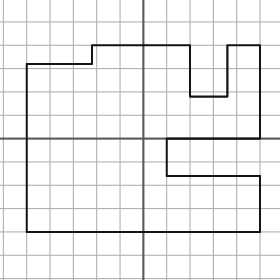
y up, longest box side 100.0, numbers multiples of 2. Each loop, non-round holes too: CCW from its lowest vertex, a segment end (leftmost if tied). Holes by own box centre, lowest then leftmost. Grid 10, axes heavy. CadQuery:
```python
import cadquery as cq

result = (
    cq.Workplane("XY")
    .moveTo(-50.0, -40.0)
    .lineTo(50.0, -40.0)
    .lineTo(50.0, -16.0)
    .lineTo(10.0, -16.0)
    .lineTo(10.0, 0.0)
    .lineTo(50.0, 0.0)
    .lineTo(50.0, 40.0)
    .lineTo(36.0, 40.0)
    .lineTo(36.0, 18.0)
    .lineTo(20.0, 18.0)
    .lineTo(20.0, 40.0)
    .lineTo(-22.0, 40.0)
    .lineTo(-22.0, 32.0)
    .lineTo(-50.0, 32.0)
    .close()
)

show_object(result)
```